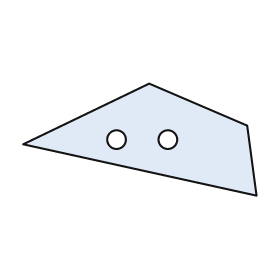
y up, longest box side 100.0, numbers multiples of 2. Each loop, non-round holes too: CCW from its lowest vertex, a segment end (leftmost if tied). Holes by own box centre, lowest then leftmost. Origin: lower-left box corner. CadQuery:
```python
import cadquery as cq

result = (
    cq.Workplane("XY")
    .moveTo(100.0, 0.0)
    .lineTo(96.0, 30.0)
    .lineTo(54.0, 48.0)
    .lineTo(0.0, 22.0)
    .close()
    .moveTo(40.0, 24.0)
    .circle(4.0)
    .moveTo(62.0, 24.0)
    .circle(4.0)
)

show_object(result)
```